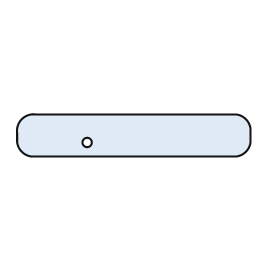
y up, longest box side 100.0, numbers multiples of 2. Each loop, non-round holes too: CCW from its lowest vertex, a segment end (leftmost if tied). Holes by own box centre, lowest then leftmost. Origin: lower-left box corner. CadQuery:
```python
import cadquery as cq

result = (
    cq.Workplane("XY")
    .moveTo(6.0, 0.0)
    .lineTo(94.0, 0.0)
    .threePointArc((98.0, 2.0), (100.0, 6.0))
    .lineTo(100.0, 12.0)
    .threePointArc((98.0, 16.0), (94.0, 18.0))
    .lineTo(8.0, 18.0)
    .threePointArc((2.0, 16.0), (0.0, 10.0))
    .lineTo(0.0, 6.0)
    .threePointArc((2.0, 2.0), (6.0, 0.0))
    .close()
    .moveTo(30.0, 6.0)
    .circle(2.0)
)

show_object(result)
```